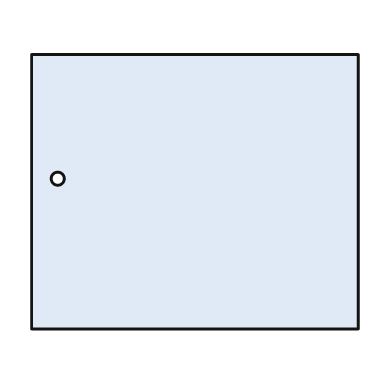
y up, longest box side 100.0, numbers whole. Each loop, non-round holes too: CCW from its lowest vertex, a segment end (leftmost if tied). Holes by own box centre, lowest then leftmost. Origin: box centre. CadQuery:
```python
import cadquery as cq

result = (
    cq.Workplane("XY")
    .moveTo(-50.0, -42.0)
    .lineTo(50.0, -42.0)
    .lineTo(50.0, 42.0)
    .lineTo(-50.0, 42.0)
    .close()
    .moveTo(-42.0, 4.0)
    .circle(2.0)
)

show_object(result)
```